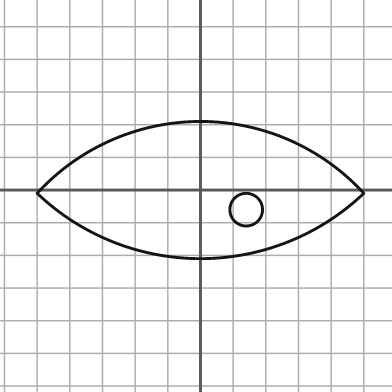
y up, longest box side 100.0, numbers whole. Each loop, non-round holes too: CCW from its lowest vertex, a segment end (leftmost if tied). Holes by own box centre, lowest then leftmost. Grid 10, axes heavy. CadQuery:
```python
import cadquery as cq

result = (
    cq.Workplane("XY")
    .moveTo(-50.0, -1.0)
    .threePointArc((0.0, -21.0), (50.0, -1.0))
    .threePointArc((0.0, 21.0), (-50.0, -1.0))
    .close()
    .moveTo(14.0, -6.0)
    .circle(5.0)
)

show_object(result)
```